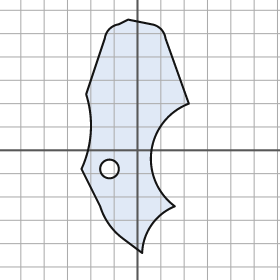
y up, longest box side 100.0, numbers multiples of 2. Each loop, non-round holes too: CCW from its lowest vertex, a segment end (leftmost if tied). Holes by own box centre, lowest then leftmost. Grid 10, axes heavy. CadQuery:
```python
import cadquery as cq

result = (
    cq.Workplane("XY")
    .moveTo(2.0, -44.0)
    .threePointArc((6.0, -32.0), (16.0, -24.0))
    .threePointArc((6.0, 0.0), (22.0, 20.0))
    .lineTo(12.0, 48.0)
    .threePointArc((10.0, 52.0), (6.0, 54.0))
    .lineTo(-4.0, 56.0)
    .lineTo(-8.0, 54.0)
    .threePointArc((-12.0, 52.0), (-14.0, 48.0))
    .lineTo(-22.0, 24.0)
    .threePointArc((-20.0, 8.0), (-24.0, -8.0))
    .lineTo(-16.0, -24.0)
    .threePointArc((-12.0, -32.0), (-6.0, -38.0))
    .close()
    .moveTo(-12.0, -8.0)
    .circle(4.0)
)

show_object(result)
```